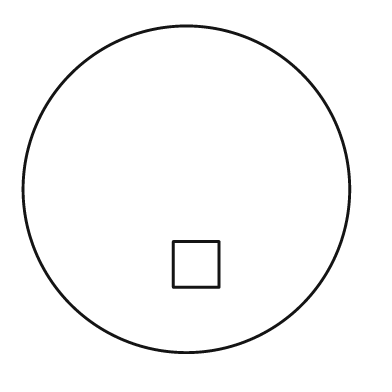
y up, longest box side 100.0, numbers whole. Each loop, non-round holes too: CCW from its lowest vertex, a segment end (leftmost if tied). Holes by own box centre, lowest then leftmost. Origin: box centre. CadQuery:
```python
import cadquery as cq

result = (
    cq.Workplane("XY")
    .moveTo(0.0, 0.0)
    .circle(50.0)
    .moveTo(-4.0, -30.0)
    .lineTo(10.0, -30.0)
    .lineTo(10.0, -16.0)
    .lineTo(-4.0, -16.0)
    .close()
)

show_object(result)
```